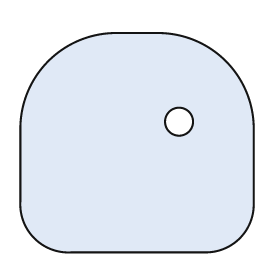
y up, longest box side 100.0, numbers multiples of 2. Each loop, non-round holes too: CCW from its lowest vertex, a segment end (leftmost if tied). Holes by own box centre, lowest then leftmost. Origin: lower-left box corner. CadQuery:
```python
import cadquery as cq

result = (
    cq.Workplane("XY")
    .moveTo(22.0, 0.0)
    .lineTo(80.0, 0.0)
    .threePointArc((94.0, 6.0), (100.0, 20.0))
    .lineTo(100.0, 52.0)
    .threePointArc((88.0, 82.0), (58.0, 94.0))
    .lineTo(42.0, 94.0)
    .threePointArc((12.0, 82.0), (0.0, 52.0))
    .lineTo(0.0, 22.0)
    .threePointArc((6.0, 6.0), (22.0, 0.0))
    .close()
    .moveTo(68.0, 56.0)
    .circle(6.0)
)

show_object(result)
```